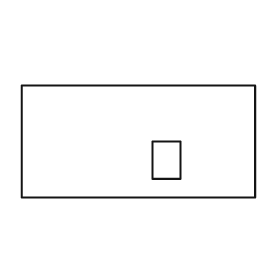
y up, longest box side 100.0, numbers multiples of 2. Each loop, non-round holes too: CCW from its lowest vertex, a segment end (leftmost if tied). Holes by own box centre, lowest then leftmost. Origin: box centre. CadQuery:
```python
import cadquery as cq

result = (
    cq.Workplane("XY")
    .moveTo(-50.0, -24.0)
    .lineTo(50.0, -24.0)
    .lineTo(50.0, 24.0)
    .lineTo(-50.0, 24.0)
    .close()
    .moveTo(6.0, -16.0)
    .lineTo(18.0, -16.0)
    .lineTo(18.0, 0.0)
    .lineTo(6.0, 0.0)
    .close()
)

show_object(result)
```